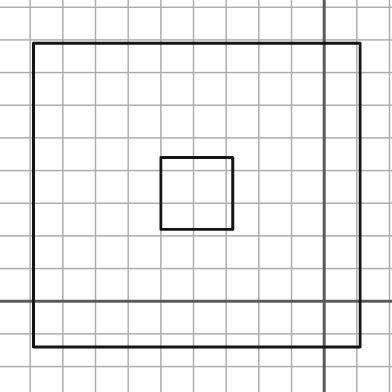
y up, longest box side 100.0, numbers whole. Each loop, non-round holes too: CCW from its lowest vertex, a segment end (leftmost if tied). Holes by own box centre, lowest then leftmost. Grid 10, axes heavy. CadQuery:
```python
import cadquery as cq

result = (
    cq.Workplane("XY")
    .moveTo(-89.0, -14.0)
    .lineTo(11.0, -14.0)
    .lineTo(11.0, 79.0)
    .lineTo(-89.0, 79.0)
    .close()
    .moveTo(-50.0, 22.0)
    .lineTo(-28.0, 22.0)
    .lineTo(-28.0, 44.0)
    .lineTo(-50.0, 44.0)
    .close()
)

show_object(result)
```